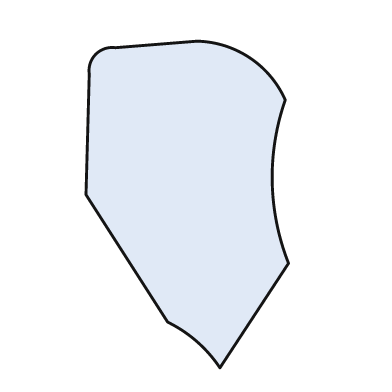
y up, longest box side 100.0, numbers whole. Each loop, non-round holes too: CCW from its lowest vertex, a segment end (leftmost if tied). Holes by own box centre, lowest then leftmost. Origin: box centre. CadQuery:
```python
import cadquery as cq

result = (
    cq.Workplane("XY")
    .moveTo(10.0, -50.0)
    .lineTo(31.0, -18.0)
    .threePointArc((26.0, 7.0), (30.0, 32.0))
    .threePointArc((19.0, 45.0), (3.0, 50.0))
    .lineTo(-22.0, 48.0)
    .threePointArc((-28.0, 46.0), (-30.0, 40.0))
    .lineTo(-31.0, 3.0)
    .lineTo(-6.0, -36.0)
    .threePointArc((3.0, -42.0), (10.0, -50.0))
    .close()
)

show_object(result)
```